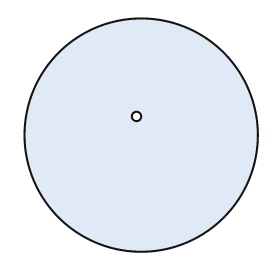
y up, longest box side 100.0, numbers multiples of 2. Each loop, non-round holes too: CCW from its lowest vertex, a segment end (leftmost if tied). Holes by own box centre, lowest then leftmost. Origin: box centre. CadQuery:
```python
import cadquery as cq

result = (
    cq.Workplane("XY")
    .moveTo(0.0, 0.0)
    .circle(50.0)
    .moveTo(-2.0, 8.0)
    .circle(2.0)
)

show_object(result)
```